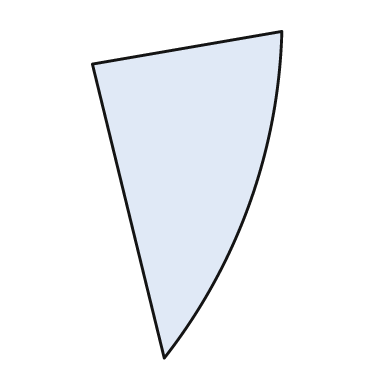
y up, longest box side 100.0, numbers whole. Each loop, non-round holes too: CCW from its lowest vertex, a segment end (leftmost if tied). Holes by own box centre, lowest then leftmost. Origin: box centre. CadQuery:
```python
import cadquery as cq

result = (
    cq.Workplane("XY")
    .moveTo(-7.0, -50.0)
    .threePointArc((19.0, -3.0), (29.0, 50.0))
    .lineTo(-29.0, 40.0)
    .close()
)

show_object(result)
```